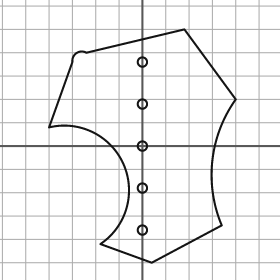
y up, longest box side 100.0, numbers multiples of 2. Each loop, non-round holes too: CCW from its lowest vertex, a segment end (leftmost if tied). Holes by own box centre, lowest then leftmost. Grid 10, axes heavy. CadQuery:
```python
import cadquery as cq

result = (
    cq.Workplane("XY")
    .moveTo(4.0, -50.0)
    .lineTo(34.0, -34.0)
    .threePointArc((30.0, -6.0), (40.0, 20.0))
    .lineTo(18.0, 50.0)
    .lineTo(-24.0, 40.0)
    .threePointArc((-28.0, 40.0), (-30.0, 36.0))
    .lineTo(-40.0, 8.0)
    .threePointArc((-8.0, -8.0), (-18.0, -42.0))
    .close()
    .moveTo(0.0, -36.0)
    .circle(2.0)
    .moveTo(0.0, -18.0)
    .circle(2.0)
    .moveTo(0.0, 0.0)
    .circle(2.0)
    .moveTo(0.0, 18.0)
    .circle(2.0)
    .moveTo(0.0, 36.0)
    .circle(2.0)
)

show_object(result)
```